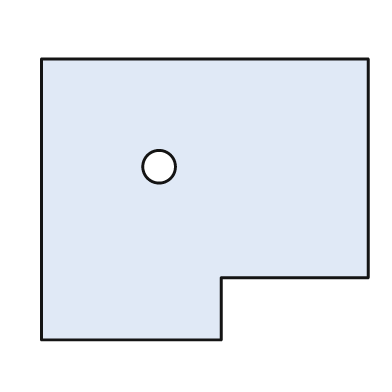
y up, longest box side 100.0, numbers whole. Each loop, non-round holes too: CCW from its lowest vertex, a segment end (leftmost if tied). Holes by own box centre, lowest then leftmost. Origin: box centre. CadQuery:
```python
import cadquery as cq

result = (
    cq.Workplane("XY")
    .moveTo(-50.0, -43.0)
    .lineTo(5.0, -43.0)
    .lineTo(5.0, -24.0)
    .lineTo(50.0, -24.0)
    .lineTo(50.0, 43.0)
    .lineTo(-50.0, 43.0)
    .close()
    .moveTo(-14.0, 10.0)
    .circle(5.0)
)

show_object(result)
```